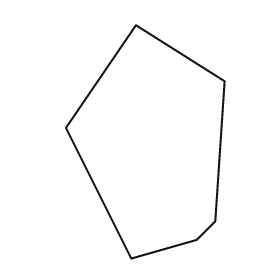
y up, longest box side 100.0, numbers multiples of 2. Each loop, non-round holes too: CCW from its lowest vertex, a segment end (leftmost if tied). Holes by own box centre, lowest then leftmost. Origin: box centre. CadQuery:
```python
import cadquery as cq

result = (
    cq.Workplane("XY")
    .moveTo(-6.0, -50.0)
    .lineTo(22.0, -42.0)
    .lineTo(30.0, -34.0)
    .lineTo(34.0, 26.0)
    .lineTo(-4.0, 50.0)
    .lineTo(-34.0, 6.0)
    .close()
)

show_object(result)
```